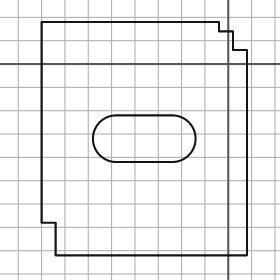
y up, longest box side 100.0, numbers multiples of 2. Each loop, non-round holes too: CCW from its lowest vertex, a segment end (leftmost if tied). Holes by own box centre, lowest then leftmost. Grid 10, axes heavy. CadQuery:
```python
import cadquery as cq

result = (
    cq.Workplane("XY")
    .moveTo(-74.0, -82.0)
    .lineTo(8.0, -82.0)
    .lineTo(8.0, 6.0)
    .lineTo(2.0, 6.0)
    .lineTo(2.0, 14.0)
    .lineTo(-4.0, 14.0)
    .lineTo(-4.0, 18.0)
    .lineTo(-80.0, 18.0)
    .lineTo(-80.0, -68.0)
    .lineTo(-74.0, -68.0)
    .close()
    .moveTo(-48.0, -42.0)
    .lineTo(-24.0, -42.0)
    .threePointArc((-14.0, -32.0), (-24.0, -22.0))
    .lineTo(-48.0, -22.0)
    .threePointArc((-58.0, -32.0), (-48.0, -42.0))
    .close()
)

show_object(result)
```